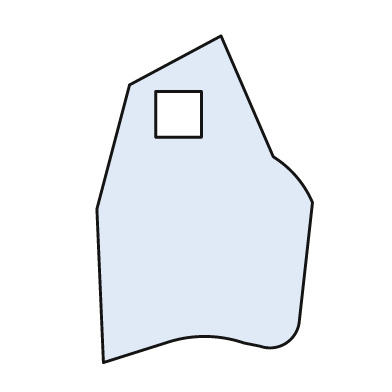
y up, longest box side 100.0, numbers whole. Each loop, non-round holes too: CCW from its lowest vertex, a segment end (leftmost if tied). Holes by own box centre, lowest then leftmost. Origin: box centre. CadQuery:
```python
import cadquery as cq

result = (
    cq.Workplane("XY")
    .moveTo(-31.0, -50.0)
    .lineTo(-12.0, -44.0)
    .threePointArc((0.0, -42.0), (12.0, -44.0))
    .lineTo(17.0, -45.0)
    .threePointArc((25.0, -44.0), (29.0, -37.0))
    .lineTo(33.0, -1.0)
    .threePointArc((28.0, 7.0), (21.0, 13.0))
    .lineTo(5.0, 50.0)
    .lineTo(-23.0, 35.0)
    .lineTo(-33.0, -3.0)
    .close()
    .moveTo(-15.0, 19.0)
    .lineTo(-1.0, 19.0)
    .lineTo(-1.0, 33.0)
    .lineTo(-15.0, 33.0)
    .close()
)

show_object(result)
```